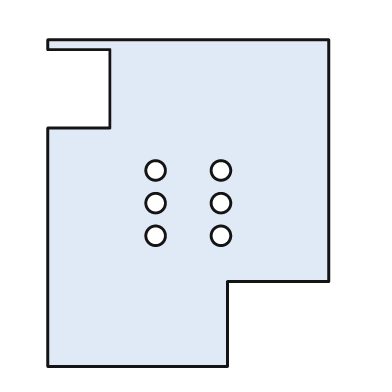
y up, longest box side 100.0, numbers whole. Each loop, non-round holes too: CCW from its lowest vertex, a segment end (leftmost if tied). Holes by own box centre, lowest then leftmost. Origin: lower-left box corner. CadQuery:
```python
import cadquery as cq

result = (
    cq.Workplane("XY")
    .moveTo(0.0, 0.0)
    .lineTo(55.0, 0.0)
    .lineTo(55.0, 26.0)
    .lineTo(86.0, 26.0)
    .lineTo(86.0, 100.0)
    .lineTo(0.0, 100.0)
    .lineTo(0.0, 97.0)
    .lineTo(19.0, 97.0)
    .lineTo(19.0, 73.0)
    .lineTo(0.0, 73.0)
    .close()
    .moveTo(33.0, 40.0)
    .circle(3.0)
    .moveTo(53.0, 40.0)
    .circle(3.0)
    .moveTo(33.0, 50.0)
    .circle(3.0)
    .moveTo(53.0, 50.0)
    .circle(3.0)
    .moveTo(33.0, 60.0)
    .circle(3.0)
    .moveTo(53.0, 60.0)
    .circle(3.0)
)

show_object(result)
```